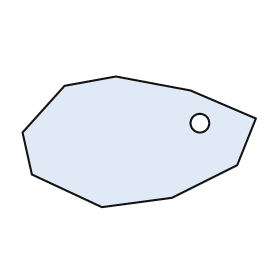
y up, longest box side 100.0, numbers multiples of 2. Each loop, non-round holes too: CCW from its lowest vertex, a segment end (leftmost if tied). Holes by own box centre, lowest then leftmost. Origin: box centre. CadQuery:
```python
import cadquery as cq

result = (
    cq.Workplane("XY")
    .moveTo(-16.0, -28.0)
    .lineTo(14.0, -24.0)
    .lineTo(42.0, -10.0)
    .lineTo(50.0, 10.0)
    .lineTo(22.0, 22.0)
    .lineTo(-10.0, 28.0)
    .lineTo(-32.0, 24.0)
    .lineTo(-50.0, 4.0)
    .lineTo(-46.0, -14.0)
    .close()
    .moveTo(26.0, 8.0)
    .circle(4.0)
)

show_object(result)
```